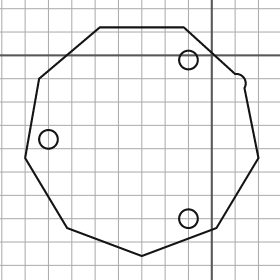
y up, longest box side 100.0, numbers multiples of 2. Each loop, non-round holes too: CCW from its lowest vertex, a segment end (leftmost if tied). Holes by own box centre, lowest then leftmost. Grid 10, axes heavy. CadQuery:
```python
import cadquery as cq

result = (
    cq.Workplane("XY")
    .moveTo(-30.0, -86.0)
    .lineTo(2.0, -74.0)
    .lineTo(20.0, -44.0)
    .lineTo(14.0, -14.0)
    .threePointArc((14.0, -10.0), (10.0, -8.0))
    .lineTo(-12.0, 12.0)
    .lineTo(-48.0, 12.0)
    .lineTo(-74.0, -10.0)
    .lineTo(-80.0, -44.0)
    .lineTo(-62.0, -74.0)
    .close()
    .moveTo(-10.0, -70.0)
    .circle(4.0)
    .moveTo(-70.0, -36.0)
    .circle(4.0)
    .moveTo(-10.0, -2.0)
    .circle(4.0)
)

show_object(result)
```